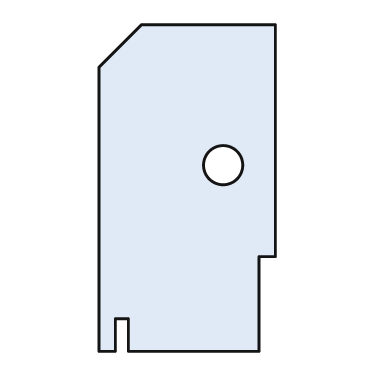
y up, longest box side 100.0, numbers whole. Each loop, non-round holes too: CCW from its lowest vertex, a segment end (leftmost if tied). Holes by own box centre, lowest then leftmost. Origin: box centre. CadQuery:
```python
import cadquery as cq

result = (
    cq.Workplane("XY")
    .moveTo(-27.0, -50.0)
    .lineTo(-22.0, -50.0)
    .lineTo(-22.0, -40.0)
    .lineTo(-18.0, -40.0)
    .lineTo(-18.0, -50.0)
    .lineTo(22.0, -50.0)
    .lineTo(22.0, -21.0)
    .lineTo(27.0, -21.0)
    .lineTo(27.0, 50.0)
    .lineTo(-14.0, 50.0)
    .lineTo(-27.0, 37.0)
    .close()
    .moveTo(11.0, 7.0)
    .circle(6.0)
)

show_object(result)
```